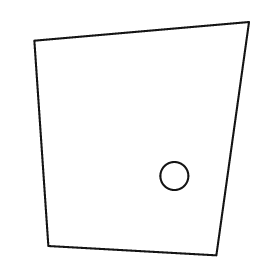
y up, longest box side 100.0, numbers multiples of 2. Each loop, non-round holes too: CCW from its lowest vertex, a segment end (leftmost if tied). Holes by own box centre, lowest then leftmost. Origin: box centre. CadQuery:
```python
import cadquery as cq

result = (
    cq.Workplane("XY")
    .moveTo(32.0, -50.0)
    .lineTo(46.0, 50.0)
    .lineTo(-46.0, 42.0)
    .lineTo(-40.0, -46.0)
    .close()
    .moveTo(14.0, -16.0)
    .circle(6.0)
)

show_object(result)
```